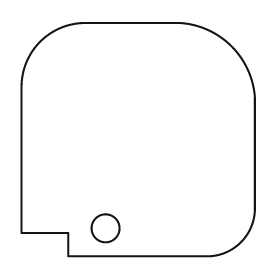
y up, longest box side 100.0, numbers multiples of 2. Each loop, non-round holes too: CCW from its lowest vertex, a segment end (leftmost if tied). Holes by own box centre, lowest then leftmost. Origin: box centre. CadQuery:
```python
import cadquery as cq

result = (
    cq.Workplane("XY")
    .moveTo(-30.0, -50.0)
    .lineTo(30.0, -50.0)
    .threePointArc((44.0, -44.0), (50.0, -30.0))
    .lineTo(50.0, 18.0)
    .threePointArc((40.0, 40.0), (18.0, 50.0))
    .lineTo(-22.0, 50.0)
    .threePointArc((-42.0, 42.0), (-50.0, 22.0))
    .lineTo(-50.0, -40.0)
    .lineTo(-30.0, -40.0)
    .close()
    .moveTo(-14.0, -38.0)
    .circle(6.0)
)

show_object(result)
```